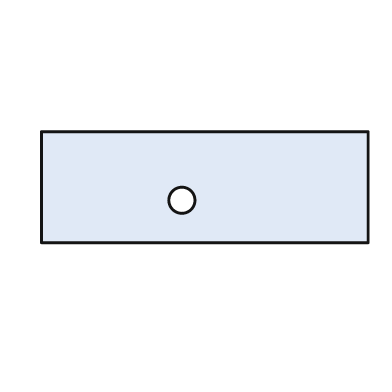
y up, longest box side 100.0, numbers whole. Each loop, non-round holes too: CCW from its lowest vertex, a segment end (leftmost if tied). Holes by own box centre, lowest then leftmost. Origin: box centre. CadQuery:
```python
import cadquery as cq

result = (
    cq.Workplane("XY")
    .moveTo(-50.0, -17.0)
    .lineTo(50.0, -17.0)
    .lineTo(50.0, 17.0)
    .lineTo(-50.0, 17.0)
    .close()
    .moveTo(-7.0, -4.0)
    .circle(4.0)
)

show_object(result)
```